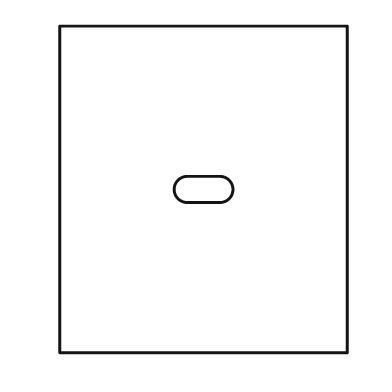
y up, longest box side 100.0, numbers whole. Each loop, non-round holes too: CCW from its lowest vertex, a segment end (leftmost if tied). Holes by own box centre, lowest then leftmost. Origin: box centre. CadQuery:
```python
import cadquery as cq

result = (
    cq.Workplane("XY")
    .moveTo(-44.0, -50.0)
    .lineTo(44.0, -50.0)
    .lineTo(44.0, 50.0)
    .lineTo(-44.0, 50.0)
    .close()
    .moveTo(-5.0, -4.0)
    .lineTo(5.0, -4.0)
    .threePointArc((9.0, 0.0), (5.0, 4.0))
    .lineTo(-5.0, 4.0)
    .threePointArc((-9.0, 0.0), (-5.0, -4.0))
    .close()
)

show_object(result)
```